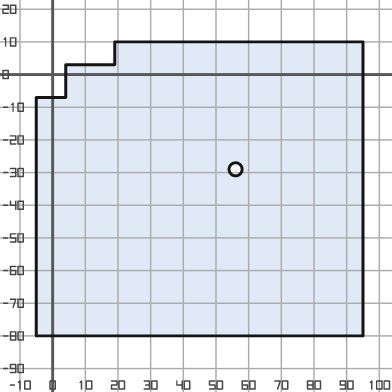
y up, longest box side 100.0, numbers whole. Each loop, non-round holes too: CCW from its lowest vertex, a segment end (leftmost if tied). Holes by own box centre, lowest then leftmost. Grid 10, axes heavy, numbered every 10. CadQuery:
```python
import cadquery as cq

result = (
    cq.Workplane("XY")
    .moveTo(-5.0, -80.0)
    .lineTo(95.0, -80.0)
    .lineTo(95.0, 10.0)
    .lineTo(19.0, 10.0)
    .lineTo(19.0, 3.0)
    .lineTo(4.0, 3.0)
    .lineTo(4.0, -7.0)
    .lineTo(-5.0, -7.0)
    .close()
    .moveTo(56.0, -29.0)
    .circle(2.0)
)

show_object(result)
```